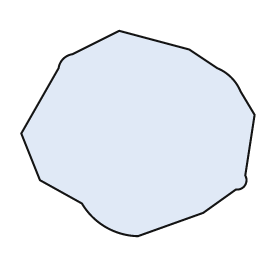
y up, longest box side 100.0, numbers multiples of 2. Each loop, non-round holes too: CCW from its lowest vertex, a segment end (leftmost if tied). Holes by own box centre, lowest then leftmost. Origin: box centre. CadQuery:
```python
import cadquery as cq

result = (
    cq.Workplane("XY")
    .moveTo(0.0, -44.0)
    .lineTo(28.0, -34.0)
    .lineTo(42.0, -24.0)
    .threePointArc((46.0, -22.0), (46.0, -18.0))
    .lineTo(50.0, 8.0)
    .lineTo(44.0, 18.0)
    .threePointArc((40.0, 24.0), (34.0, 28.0))
    .lineTo(22.0, 36.0)
    .lineTo(-8.0, 44.0)
    .lineTo(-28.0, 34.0)
    .threePointArc((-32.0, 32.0), (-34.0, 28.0))
    .lineTo(-50.0, 0.0)
    .lineTo(-42.0, -20.0)
    .lineTo(-24.0, -30.0)
    .threePointArc((-14.0, -40.0), (0.0, -44.0))
    .close()
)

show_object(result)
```